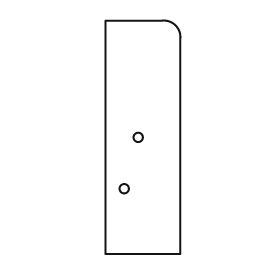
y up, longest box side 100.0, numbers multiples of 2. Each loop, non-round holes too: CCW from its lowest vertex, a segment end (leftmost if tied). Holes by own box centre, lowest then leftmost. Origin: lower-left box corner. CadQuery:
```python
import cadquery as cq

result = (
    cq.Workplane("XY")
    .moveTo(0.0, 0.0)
    .lineTo(32.0, 0.0)
    .lineTo(32.0, 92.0)
    .threePointArc((30.0, 98.0), (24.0, 100.0))
    .lineTo(0.0, 100.0)
    .close()
    .moveTo(8.0, 28.0)
    .circle(2.0)
    .moveTo(14.0, 50.0)
    .circle(2.0)
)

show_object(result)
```